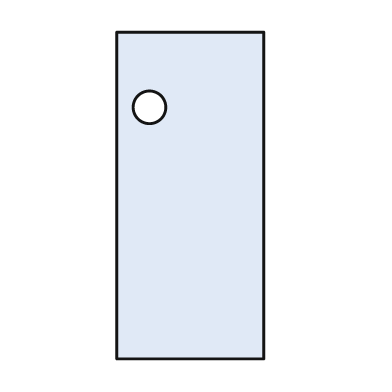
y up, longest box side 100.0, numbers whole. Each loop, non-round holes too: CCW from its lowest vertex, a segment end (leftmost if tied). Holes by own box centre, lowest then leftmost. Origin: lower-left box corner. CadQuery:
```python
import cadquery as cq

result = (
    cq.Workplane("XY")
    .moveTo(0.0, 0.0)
    .lineTo(45.0, 0.0)
    .lineTo(45.0, 100.0)
    .lineTo(0.0, 100.0)
    .close()
    .moveTo(10.0, 77.0)
    .circle(5.0)
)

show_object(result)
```